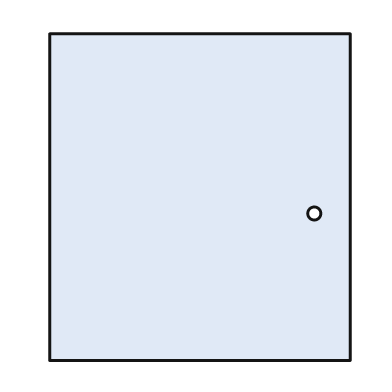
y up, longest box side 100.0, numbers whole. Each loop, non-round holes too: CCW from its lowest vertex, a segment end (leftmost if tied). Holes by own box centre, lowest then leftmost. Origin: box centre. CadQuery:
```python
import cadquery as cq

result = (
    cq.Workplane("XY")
    .moveTo(-46.0, -50.0)
    .lineTo(46.0, -50.0)
    .lineTo(46.0, 50.0)
    .lineTo(-46.0, 50.0)
    .close()
    .moveTo(35.0, -5.0)
    .circle(2.0)
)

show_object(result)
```